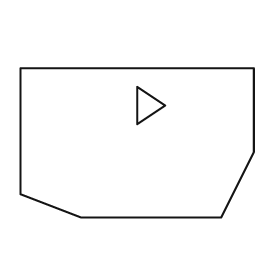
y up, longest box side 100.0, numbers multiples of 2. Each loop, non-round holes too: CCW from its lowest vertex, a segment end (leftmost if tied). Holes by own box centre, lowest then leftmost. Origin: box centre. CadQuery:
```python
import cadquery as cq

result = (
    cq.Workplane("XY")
    .moveTo(-24.0, -32.0)
    .lineTo(36.0, -32.0)
    .lineTo(50.0, -4.0)
    .lineTo(50.0, 32.0)
    .lineTo(-50.0, 32.0)
    .lineTo(-50.0, -22.0)
    .close()
    .moveTo(0.0, 8.0)
    .lineTo(12.0, 16.0)
    .lineTo(0.0, 24.0)
    .close()
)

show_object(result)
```